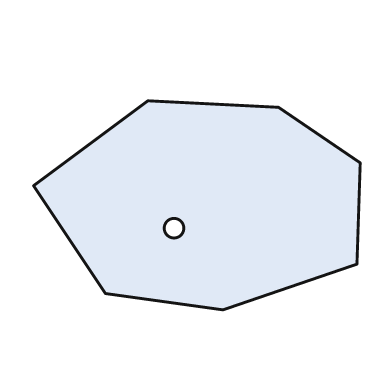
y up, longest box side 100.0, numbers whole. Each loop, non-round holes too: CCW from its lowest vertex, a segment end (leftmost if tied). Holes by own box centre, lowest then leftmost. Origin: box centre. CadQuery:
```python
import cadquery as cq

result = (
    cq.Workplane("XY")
    .moveTo(8.0, -32.0)
    .lineTo(49.0, -18.0)
    .lineTo(50.0, 13.0)
    .lineTo(25.0, 30.0)
    .lineTo(-15.0, 32.0)
    .lineTo(-50.0, 6.0)
    .lineTo(-28.0, -27.0)
    .close()
    .moveTo(-7.0, -7.0)
    .circle(3.0)
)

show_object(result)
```